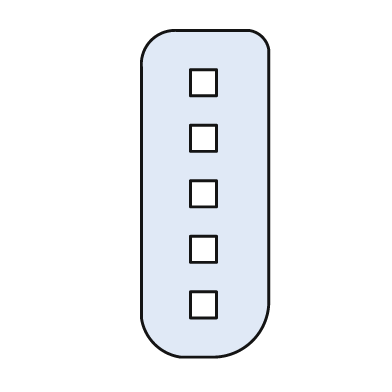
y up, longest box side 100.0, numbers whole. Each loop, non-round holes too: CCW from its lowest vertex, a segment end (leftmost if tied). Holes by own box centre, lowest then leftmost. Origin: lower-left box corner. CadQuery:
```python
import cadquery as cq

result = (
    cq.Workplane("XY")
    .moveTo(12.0, 0.0)
    .lineTo(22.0, 0.0)
    .threePointArc((34.0, 5.0), (39.0, 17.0))
    .lineTo(39.0, 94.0)
    .threePointArc((37.0, 98.0), (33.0, 100.0))
    .lineTo(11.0, 100.0)
    .threePointArc((3.0, 97.0), (0.0, 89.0))
    .lineTo(0.0, 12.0)
    .threePointArc((4.0, 4.0), (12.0, 0.0))
    .close()
    .moveTo(15.0, 12.0)
    .lineTo(23.0, 12.0)
    .lineTo(23.0, 20.0)
    .lineTo(15.0, 20.0)
    .close()
    .moveTo(15.0, 29.0)
    .lineTo(23.0, 29.0)
    .lineTo(23.0, 37.0)
    .lineTo(15.0, 37.0)
    .close()
    .moveTo(15.0, 46.0)
    .lineTo(23.0, 46.0)
    .lineTo(23.0, 54.0)
    .lineTo(15.0, 54.0)
    .close()
    .moveTo(15.0, 63.0)
    .lineTo(23.0, 63.0)
    .lineTo(23.0, 71.0)
    .lineTo(15.0, 71.0)
    .close()
    .moveTo(15.0, 80.0)
    .lineTo(23.0, 80.0)
    .lineTo(23.0, 88.0)
    .lineTo(15.0, 88.0)
    .close()
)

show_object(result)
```